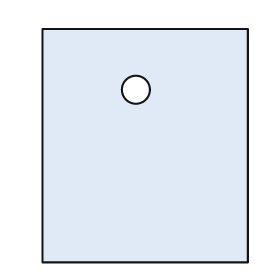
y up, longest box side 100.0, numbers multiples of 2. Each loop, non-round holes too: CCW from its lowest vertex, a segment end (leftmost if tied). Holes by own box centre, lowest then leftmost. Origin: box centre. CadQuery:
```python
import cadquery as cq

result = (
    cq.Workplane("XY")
    .moveTo(-44.0, -50.0)
    .lineTo(44.0, -50.0)
    .lineTo(44.0, 50.0)
    .lineTo(-44.0, 50.0)
    .close()
    .moveTo(-4.0, 24.0)
    .circle(6.0)
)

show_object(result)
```